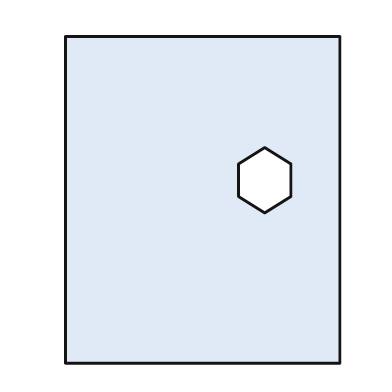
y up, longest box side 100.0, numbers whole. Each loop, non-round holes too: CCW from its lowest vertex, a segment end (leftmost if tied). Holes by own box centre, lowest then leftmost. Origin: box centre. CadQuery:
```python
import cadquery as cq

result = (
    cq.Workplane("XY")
    .moveTo(-42.0, -50.0)
    .lineTo(42.0, -50.0)
    .lineTo(42.0, 50.0)
    .lineTo(-42.0, 50.0)
    .close()
    .moveTo(19.0, -4.0)
    .lineTo(27.0, 1.0)
    .lineTo(27.0, 11.0)
    .lineTo(19.0, 16.0)
    .lineTo(11.0, 11.0)
    .lineTo(11.0, 1.0)
    .close()
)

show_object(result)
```